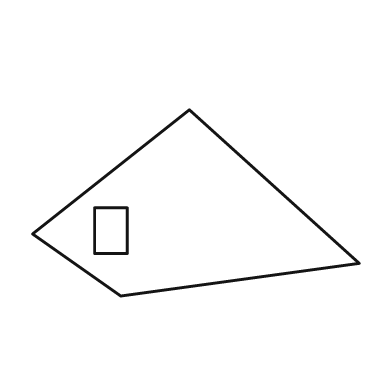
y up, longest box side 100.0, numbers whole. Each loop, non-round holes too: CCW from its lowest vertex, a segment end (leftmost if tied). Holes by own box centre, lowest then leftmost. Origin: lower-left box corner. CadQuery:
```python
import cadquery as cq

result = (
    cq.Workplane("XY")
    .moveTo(27.0, 0.0)
    .lineTo(100.0, 10.0)
    .lineTo(48.0, 57.0)
    .lineTo(0.0, 19.0)
    .close()
    .moveTo(19.0, 13.0)
    .lineTo(29.0, 13.0)
    .lineTo(29.0, 27.0)
    .lineTo(19.0, 27.0)
    .close()
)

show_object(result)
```